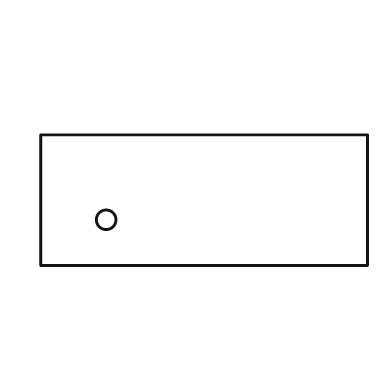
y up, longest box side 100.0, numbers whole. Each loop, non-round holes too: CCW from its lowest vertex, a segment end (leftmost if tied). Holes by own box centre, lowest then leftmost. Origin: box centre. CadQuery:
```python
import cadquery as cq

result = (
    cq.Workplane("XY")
    .moveTo(-50.0, -20.0)
    .lineTo(50.0, -20.0)
    .lineTo(50.0, 20.0)
    .lineTo(-50.0, 20.0)
    .close()
    .moveTo(-30.0, -6.0)
    .circle(3.0)
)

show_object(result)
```